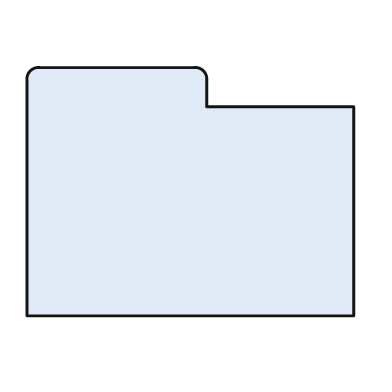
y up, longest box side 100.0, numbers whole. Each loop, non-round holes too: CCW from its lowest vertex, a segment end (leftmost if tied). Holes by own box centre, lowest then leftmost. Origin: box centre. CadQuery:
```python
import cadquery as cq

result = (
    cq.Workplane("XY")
    .moveTo(-50.0, -38.0)
    .lineTo(50.0, -38.0)
    .lineTo(50.0, 26.0)
    .lineTo(5.0, 26.0)
    .lineTo(5.0, 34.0)
    .threePointArc((4.0, 37.0), (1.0, 38.0))
    .lineTo(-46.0, 38.0)
    .threePointArc((-49.0, 37.0), (-50.0, 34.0))
    .close()
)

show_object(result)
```